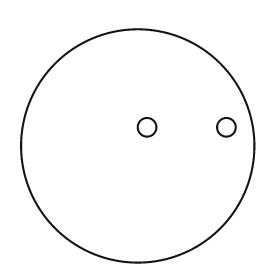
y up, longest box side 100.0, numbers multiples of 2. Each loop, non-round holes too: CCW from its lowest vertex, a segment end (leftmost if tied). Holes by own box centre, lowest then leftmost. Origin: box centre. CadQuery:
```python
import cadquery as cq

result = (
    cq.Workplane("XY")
    .moveTo(0.0, 0.0)
    .circle(50.0)
    .moveTo(4.0, 8.0)
    .circle(4.0)
    .moveTo(38.0, 8.0)
    .circle(4.0)
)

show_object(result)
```